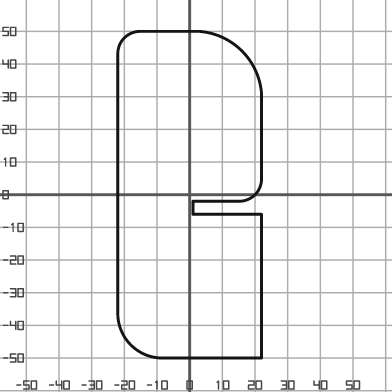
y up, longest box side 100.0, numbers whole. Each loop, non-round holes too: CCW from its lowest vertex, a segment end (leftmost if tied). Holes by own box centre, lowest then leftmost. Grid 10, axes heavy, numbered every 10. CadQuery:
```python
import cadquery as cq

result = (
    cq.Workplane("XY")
    .moveTo(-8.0, -50.0)
    .lineTo(22.0, -50.0)
    .lineTo(22.0, -6.0)
    .lineTo(1.0, -6.0)
    .lineTo(1.0, -2.0)
    .lineTo(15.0, -2.0)
    .threePointArc((20.0, 0.0), (22.0, 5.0))
    .lineTo(22.0, 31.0)
    .threePointArc((16.0, 44.0), (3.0, 50.0))
    .lineTo(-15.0, 50.0)
    .threePointArc((-20.0, 48.0), (-22.0, 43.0))
    .lineTo(-22.0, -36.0)
    .threePointArc((-18.0, -46.0), (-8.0, -50.0))
    .close()
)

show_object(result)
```